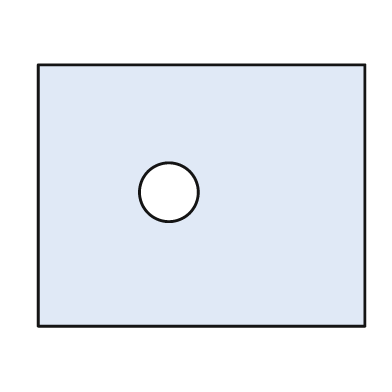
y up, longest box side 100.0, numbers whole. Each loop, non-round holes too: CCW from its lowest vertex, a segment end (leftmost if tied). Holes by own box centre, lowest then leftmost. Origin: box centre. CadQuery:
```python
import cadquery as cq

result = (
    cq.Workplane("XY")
    .moveTo(-50.0, -40.0)
    .lineTo(50.0, -40.0)
    .lineTo(50.0, 40.0)
    .lineTo(-50.0, 40.0)
    .close()
    .moveTo(-10.0, 1.0)
    .circle(9.0)
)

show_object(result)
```